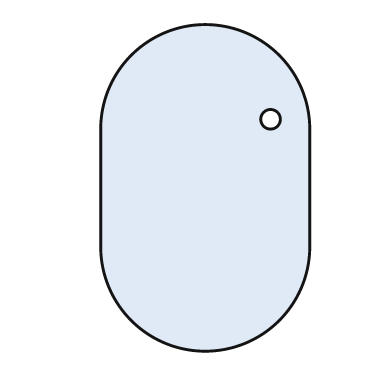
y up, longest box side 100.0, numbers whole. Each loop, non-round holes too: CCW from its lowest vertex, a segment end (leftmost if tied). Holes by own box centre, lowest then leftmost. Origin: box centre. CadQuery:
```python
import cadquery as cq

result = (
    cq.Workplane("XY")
    .moveTo(-32.0, -18.0)
    .threePointArc((0.0, -50.0), (32.0, -18.0))
    .lineTo(32.0, 18.0)
    .threePointArc((0.0, 50.0), (-32.0, 18.0))
    .close()
    .moveTo(20.0, 21.0)
    .circle(3.0)
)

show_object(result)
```